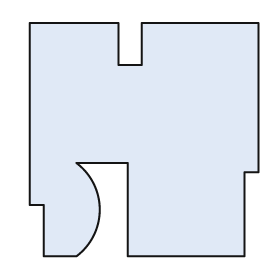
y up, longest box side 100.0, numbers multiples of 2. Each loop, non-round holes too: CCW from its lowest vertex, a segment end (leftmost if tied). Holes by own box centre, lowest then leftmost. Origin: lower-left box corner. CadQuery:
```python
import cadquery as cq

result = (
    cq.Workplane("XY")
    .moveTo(6.0, 0.0)
    .lineTo(20.0, 0.0)
    .threePointArc((30.0, 20.0), (20.0, 40.0))
    .lineTo(42.0, 40.0)
    .lineTo(42.0, 0.0)
    .lineTo(92.0, 0.0)
    .lineTo(92.0, 36.0)
    .lineTo(98.0, 36.0)
    .lineTo(98.0, 100.0)
    .lineTo(48.0, 100.0)
    .lineTo(48.0, 82.0)
    .lineTo(38.0, 82.0)
    .lineTo(38.0, 100.0)
    .lineTo(0.0, 100.0)
    .lineTo(0.0, 22.0)
    .lineTo(6.0, 22.0)
    .close()
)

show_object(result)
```